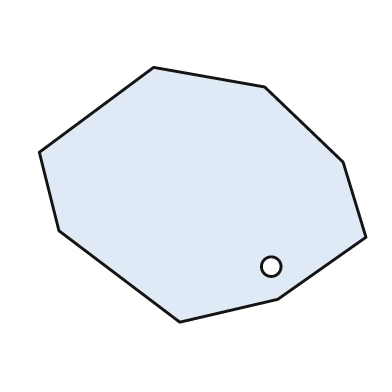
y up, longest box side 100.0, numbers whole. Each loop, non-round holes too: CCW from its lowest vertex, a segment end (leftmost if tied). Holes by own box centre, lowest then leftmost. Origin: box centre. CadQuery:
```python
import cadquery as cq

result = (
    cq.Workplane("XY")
    .moveTo(-7.0, -39.0)
    .lineTo(23.0, -32.0)
    .lineTo(50.0, -13.0)
    .lineTo(43.0, 10.0)
    .lineTo(19.0, 33.0)
    .lineTo(-15.0, 39.0)
    .lineTo(-50.0, 13.0)
    .lineTo(-44.0, -11.0)
    .close()
    .moveTo(21.0, -22.0)
    .circle(3.0)
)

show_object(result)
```